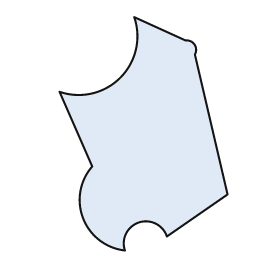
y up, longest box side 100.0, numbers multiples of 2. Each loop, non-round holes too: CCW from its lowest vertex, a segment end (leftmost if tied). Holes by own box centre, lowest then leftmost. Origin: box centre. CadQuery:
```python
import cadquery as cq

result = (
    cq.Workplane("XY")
    .moveTo(-8.0, -50.0)
    .threePointArc((-2.0, -38.0), (10.0, -44.0))
    .lineTo(36.0, -26.0)
    .lineTo(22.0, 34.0)
    .threePointArc((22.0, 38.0), (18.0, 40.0))
    .lineTo(-4.0, 50.0)
    .threePointArc((-10.0, 24.0), (-36.0, 18.0))
    .lineTo(-22.0, -14.0)
    .threePointArc((-26.0, -36.0), (-8.0, -50.0))
    .close()
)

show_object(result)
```